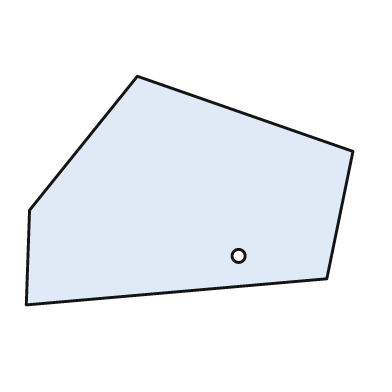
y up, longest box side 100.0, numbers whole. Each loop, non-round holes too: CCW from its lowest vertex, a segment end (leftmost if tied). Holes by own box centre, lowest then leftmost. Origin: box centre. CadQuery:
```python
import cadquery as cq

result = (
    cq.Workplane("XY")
    .moveTo(-50.0, -35.0)
    .lineTo(42.0, -27.0)
    .lineTo(50.0, 12.0)
    .lineTo(-16.0, 35.0)
    .lineTo(-49.0, -6.0)
    .close()
    .moveTo(15.0, -20.0)
    .circle(2.0)
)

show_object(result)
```